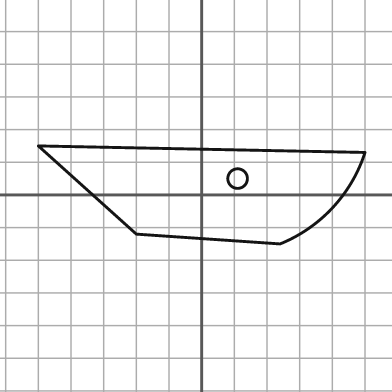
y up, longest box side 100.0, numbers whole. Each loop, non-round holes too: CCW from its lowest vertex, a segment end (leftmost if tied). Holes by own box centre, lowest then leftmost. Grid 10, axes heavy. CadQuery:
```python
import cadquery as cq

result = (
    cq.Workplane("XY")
    .moveTo(24.0, -15.0)
    .threePointArc((40.0, -4.0), (50.0, 13.0))
    .lineTo(-50.0, 15.0)
    .lineTo(-20.0, -12.0)
    .close()
    .moveTo(11.0, 5.0)
    .circle(3.0)
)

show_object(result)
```